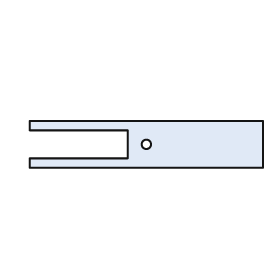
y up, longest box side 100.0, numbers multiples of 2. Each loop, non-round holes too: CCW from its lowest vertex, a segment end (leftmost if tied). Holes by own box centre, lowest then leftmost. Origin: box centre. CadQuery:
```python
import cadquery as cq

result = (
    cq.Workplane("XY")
    .moveTo(-50.0, -10.0)
    .lineTo(50.0, -10.0)
    .lineTo(50.0, 10.0)
    .lineTo(-50.0, 10.0)
    .lineTo(-50.0, 6.0)
    .lineTo(-8.0, 6.0)
    .lineTo(-8.0, -6.0)
    .lineTo(-50.0, -6.0)
    .close()
    .moveTo(0.0, 0.0)
    .circle(2.0)
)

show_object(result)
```